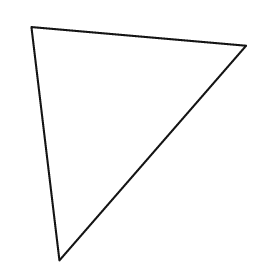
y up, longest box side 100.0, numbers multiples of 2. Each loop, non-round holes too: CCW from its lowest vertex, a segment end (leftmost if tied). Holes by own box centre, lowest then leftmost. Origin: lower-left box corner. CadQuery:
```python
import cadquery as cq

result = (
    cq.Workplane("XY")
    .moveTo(12.0, 0.0)
    .lineTo(92.0, 92.0)
    .lineTo(0.0, 100.0)
    .close()
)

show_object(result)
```